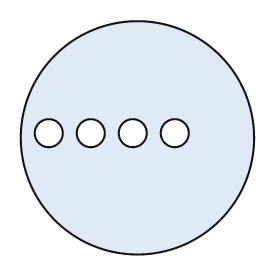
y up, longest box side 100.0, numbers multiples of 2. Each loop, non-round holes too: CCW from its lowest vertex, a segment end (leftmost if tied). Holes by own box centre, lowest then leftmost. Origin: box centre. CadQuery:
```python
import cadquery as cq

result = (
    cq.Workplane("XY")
    .moveTo(0.0, 0.0)
    .circle(50.0)
    .moveTo(-38.0, 2.0)
    .circle(6.0)
    .moveTo(-20.0, 2.0)
    .circle(6.0)
    .moveTo(-2.0, 2.0)
    .circle(6.0)
    .moveTo(16.0, 2.0)
    .circle(6.0)
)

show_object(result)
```